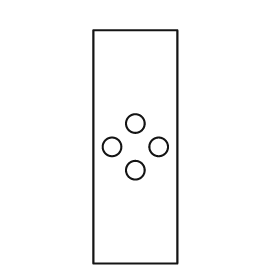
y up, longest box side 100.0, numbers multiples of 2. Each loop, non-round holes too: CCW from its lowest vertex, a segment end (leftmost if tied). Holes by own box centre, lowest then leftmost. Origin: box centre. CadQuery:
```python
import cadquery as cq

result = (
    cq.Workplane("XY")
    .moveTo(-18.0, -50.0)
    .lineTo(18.0, -50.0)
    .lineTo(18.0, 50.0)
    .lineTo(-18.0, 50.0)
    .close()
    .moveTo(0.0, -10.0)
    .circle(4.0)
    .moveTo(-10.0, 0.0)
    .circle(4.0)
    .moveTo(10.0, 0.0)
    .circle(4.0)
    .moveTo(0.0, 10.0)
    .circle(4.0)
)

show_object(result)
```